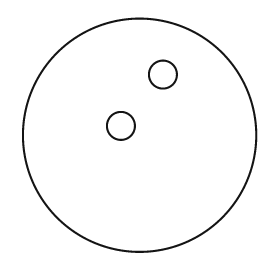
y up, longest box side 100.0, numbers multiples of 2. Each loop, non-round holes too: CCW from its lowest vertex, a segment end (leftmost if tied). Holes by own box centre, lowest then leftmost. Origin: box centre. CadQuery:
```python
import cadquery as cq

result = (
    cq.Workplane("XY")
    .moveTo(0.0, 0.0)
    .circle(50.0)
    .moveTo(-8.0, 4.0)
    .circle(6.0)
    .moveTo(10.0, 26.0)
    .circle(6.0)
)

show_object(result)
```